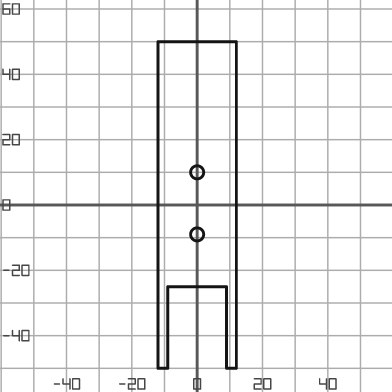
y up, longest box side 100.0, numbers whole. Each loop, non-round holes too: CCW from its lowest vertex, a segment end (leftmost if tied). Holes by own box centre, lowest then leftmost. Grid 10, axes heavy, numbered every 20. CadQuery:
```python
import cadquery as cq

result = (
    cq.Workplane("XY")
    .moveTo(-12.0, -50.0)
    .lineTo(-9.0, -50.0)
    .lineTo(-9.0, -25.0)
    .lineTo(9.0, -25.0)
    .lineTo(9.0, -50.0)
    .lineTo(12.0, -50.0)
    .lineTo(12.0, 50.0)
    .lineTo(-12.0, 50.0)
    .close()
    .moveTo(0.0, -9.0)
    .circle(2.0)
    .moveTo(0.0, 10.0)
    .circle(2.0)
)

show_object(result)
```